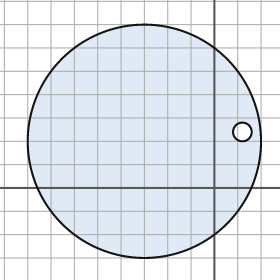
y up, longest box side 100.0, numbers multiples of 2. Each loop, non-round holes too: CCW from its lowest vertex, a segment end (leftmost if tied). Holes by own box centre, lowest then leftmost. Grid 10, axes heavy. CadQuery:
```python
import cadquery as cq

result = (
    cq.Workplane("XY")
    .moveTo(-30.0, 20.0)
    .circle(50.0)
    .moveTo(12.0, 24.0)
    .circle(4.0)
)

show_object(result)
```